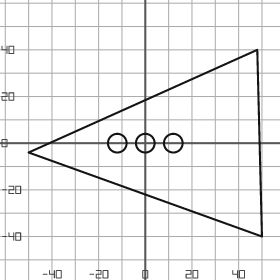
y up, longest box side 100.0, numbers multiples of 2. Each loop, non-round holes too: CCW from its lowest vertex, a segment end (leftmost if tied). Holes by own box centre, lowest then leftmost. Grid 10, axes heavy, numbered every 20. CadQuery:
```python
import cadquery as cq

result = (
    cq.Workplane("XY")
    .moveTo(50.0, -40.0)
    .lineTo(48.0, 40.0)
    .lineTo(-50.0, -4.0)
    .close()
    .moveTo(-12.0, 0.0)
    .circle(4.0)
    .moveTo(0.0, 0.0)
    .circle(4.0)
    .moveTo(12.0, 0.0)
    .circle(4.0)
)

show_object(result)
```